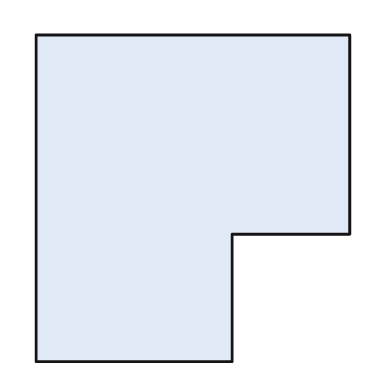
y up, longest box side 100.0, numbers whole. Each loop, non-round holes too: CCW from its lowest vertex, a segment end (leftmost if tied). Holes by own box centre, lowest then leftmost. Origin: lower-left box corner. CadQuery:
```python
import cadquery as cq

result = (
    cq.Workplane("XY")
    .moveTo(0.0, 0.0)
    .lineTo(60.0, 0.0)
    .lineTo(60.0, 39.0)
    .lineTo(96.0, 39.0)
    .lineTo(96.0, 100.0)
    .lineTo(0.0, 100.0)
    .close()
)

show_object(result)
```